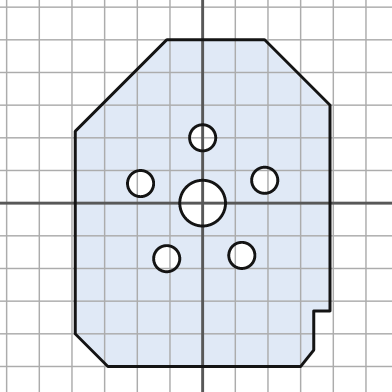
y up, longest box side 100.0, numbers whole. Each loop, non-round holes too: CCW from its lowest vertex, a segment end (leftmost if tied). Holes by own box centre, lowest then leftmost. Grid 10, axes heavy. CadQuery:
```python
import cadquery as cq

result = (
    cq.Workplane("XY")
    .moveTo(-29.0, -50.0)
    .lineTo(30.0, -50.0)
    .lineTo(34.0, -45.0)
    .lineTo(34.0, -33.0)
    .lineTo(39.0, -33.0)
    .lineTo(39.0, 30.0)
    .lineTo(19.0, 50.0)
    .lineTo(-11.0, 50.0)
    .lineTo(-39.0, 22.0)
    .lineTo(-39.0, -40.0)
    .close()
    .moveTo(-11.0, -17.0)
    .circle(4.0)
    .moveTo(12.0, -16.0)
    .circle(4.0)
    .moveTo(0.0, 0.0)
    .circle(7.0)
    .moveTo(-19.0, 6.0)
    .circle(4.0)
    .moveTo(19.0, 7.0)
    .circle(4.0)
    .moveTo(0.0, 20.0)
    .circle(4.0)
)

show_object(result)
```